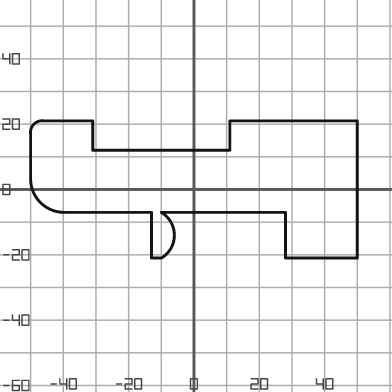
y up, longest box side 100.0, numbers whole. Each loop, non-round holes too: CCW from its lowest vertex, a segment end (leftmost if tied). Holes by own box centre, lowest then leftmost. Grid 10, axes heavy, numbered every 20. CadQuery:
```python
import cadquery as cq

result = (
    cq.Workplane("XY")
    .moveTo(-13.0, -21.0)
    .lineTo(-10.0, -21.0)
    .threePointArc((-6.0, -14.0), (-10.0, -7.0))
    .lineTo(28.0, -7.0)
    .lineTo(28.0, -21.0)
    .lineTo(50.0, -21.0)
    .lineTo(50.0, 21.0)
    .lineTo(11.0, 21.0)
    .lineTo(11.0, 12.0)
    .lineTo(-31.0, 12.0)
    .lineTo(-31.0, 21.0)
    .lineTo(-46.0, 21.0)
    .threePointArc((-49.0, 20.0), (-50.0, 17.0))
    .lineTo(-50.0, 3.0)
    .threePointArc((-47.0, -4.0), (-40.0, -7.0))
    .lineTo(-13.0, -7.0)
    .close()
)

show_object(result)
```